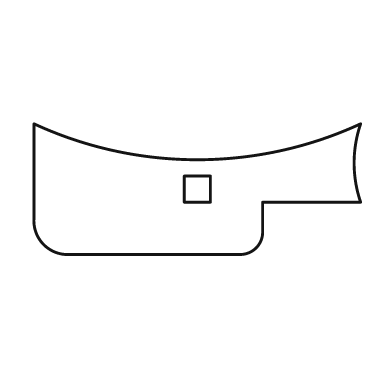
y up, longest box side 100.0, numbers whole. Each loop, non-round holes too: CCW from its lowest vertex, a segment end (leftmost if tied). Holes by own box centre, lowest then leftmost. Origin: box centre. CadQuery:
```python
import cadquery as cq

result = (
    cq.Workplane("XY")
    .moveTo(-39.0, -20.0)
    .lineTo(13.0, -20.0)
    .threePointArc((18.0, -18.0), (20.0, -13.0))
    .lineTo(20.0, -4.0)
    .lineTo(50.0, -4.0)
    .threePointArc((48.0, 8.0), (50.0, 20.0))
    .threePointArc((0.0, 9.0), (-50.0, 20.0))
    .lineTo(-50.0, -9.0)
    .threePointArc((-47.0, -17.0), (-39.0, -20.0))
    .close()
    .moveTo(-4.0, -4.0)
    .lineTo(4.0, -4.0)
    .lineTo(4.0, 4.0)
    .lineTo(-4.0, 4.0)
    .close()
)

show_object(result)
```